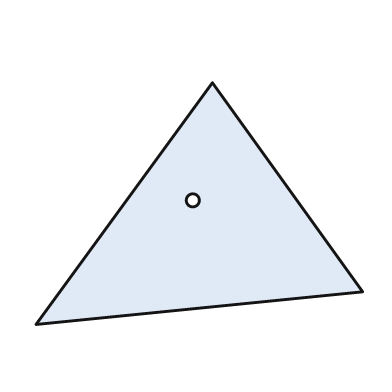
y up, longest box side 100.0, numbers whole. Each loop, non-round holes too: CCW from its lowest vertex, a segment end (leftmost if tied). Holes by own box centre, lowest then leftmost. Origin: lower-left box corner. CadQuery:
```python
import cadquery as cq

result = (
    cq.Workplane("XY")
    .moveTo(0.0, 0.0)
    .lineTo(100.0, 10.0)
    .lineTo(54.0, 74.0)
    .close()
    .moveTo(48.0, 38.0)
    .circle(2.0)
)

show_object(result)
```